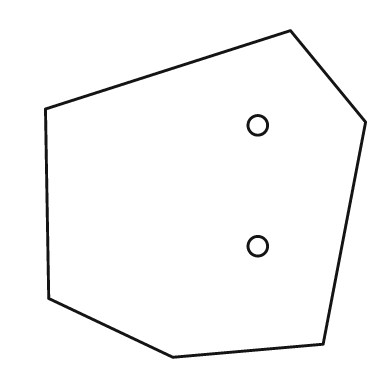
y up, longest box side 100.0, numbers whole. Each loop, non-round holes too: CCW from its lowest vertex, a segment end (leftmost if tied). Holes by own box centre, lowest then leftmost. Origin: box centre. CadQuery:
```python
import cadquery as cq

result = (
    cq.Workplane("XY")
    .moveTo(-10.0, -50.0)
    .lineTo(36.0, -46.0)
    .lineTo(49.0, 22.0)
    .lineTo(26.0, 50.0)
    .lineTo(-49.0, 26.0)
    .lineTo(-48.0, -32.0)
    .close()
    .moveTo(16.0, -16.0)
    .circle(3.0)
    .moveTo(16.0, 21.0)
    .circle(3.0)
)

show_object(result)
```